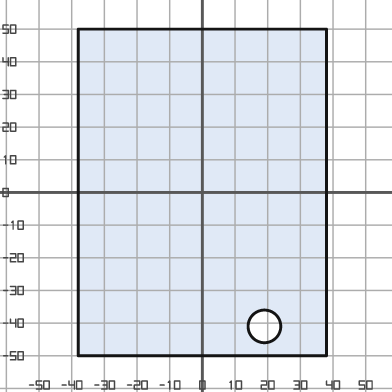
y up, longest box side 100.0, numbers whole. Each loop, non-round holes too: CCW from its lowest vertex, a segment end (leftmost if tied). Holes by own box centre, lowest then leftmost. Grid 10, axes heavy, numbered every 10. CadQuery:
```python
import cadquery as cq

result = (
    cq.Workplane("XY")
    .moveTo(-38.0, -50.0)
    .lineTo(38.0, -50.0)
    .lineTo(38.0, 50.0)
    .lineTo(-38.0, 50.0)
    .close()
    .moveTo(19.0, -41.0)
    .circle(5.0)
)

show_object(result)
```